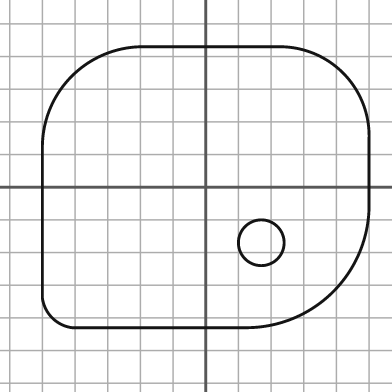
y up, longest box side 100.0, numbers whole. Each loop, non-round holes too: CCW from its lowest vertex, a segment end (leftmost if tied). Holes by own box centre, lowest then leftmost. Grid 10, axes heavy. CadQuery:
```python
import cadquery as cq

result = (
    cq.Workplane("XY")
    .moveTo(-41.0, -43.0)
    .lineTo(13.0, -43.0)
    .threePointArc((39.0, -32.0), (50.0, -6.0))
    .lineTo(50.0, 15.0)
    .threePointArc((42.0, 35.0), (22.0, 43.0))
    .lineTo(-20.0, 43.0)
    .threePointArc((-41.0, 34.0), (-50.0, 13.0))
    .lineTo(-50.0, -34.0)
    .threePointArc((-47.0, -40.0), (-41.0, -43.0))
    .close()
    .moveTo(17.0, -17.0)
    .circle(7.0)
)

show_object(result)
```